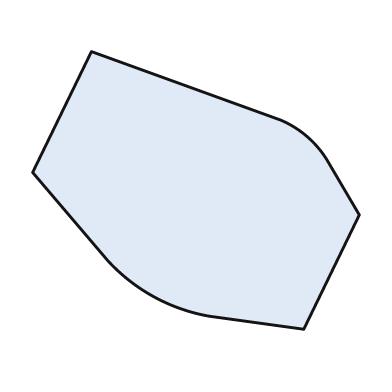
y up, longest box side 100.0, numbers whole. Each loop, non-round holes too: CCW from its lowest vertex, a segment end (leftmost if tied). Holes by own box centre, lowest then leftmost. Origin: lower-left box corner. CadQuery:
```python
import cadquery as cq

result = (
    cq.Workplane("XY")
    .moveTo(83.0, 0.0)
    .lineTo(100.0, 35.0)
    .lineTo(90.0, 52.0)
    .threePointArc((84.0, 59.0), (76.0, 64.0))
    .lineTo(18.0, 85.0)
    .lineTo(0.0, 48.0)
    .lineTo(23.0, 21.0)
    .threePointArc((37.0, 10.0), (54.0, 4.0))
    .close()
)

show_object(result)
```